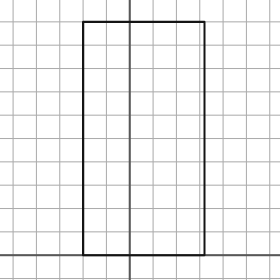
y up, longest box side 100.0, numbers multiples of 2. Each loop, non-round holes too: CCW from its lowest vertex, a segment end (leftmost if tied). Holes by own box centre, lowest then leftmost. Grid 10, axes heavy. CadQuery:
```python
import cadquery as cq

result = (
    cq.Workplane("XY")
    .moveTo(-20.0, 0.0)
    .lineTo(32.0, 0.0)
    .lineTo(32.0, 100.0)
    .lineTo(-20.0, 100.0)
    .close()
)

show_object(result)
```